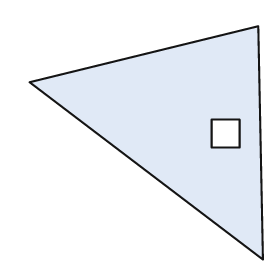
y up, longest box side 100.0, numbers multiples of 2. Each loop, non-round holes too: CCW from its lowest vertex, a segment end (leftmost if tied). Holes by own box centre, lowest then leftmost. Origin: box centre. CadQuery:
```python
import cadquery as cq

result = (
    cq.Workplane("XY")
    .moveTo(50.0, -50.0)
    .lineTo(48.0, 50.0)
    .lineTo(-50.0, 26.0)
    .close()
    .moveTo(28.0, -2.0)
    .lineTo(40.0, -2.0)
    .lineTo(40.0, 10.0)
    .lineTo(28.0, 10.0)
    .close()
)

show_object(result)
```